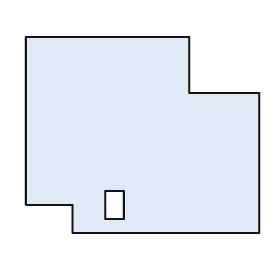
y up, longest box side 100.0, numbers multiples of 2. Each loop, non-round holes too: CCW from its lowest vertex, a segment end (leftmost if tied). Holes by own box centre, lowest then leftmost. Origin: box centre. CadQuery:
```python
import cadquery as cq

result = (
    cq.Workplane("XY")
    .moveTo(-30.0, -42.0)
    .lineTo(50.0, -42.0)
    .lineTo(50.0, 18.0)
    .lineTo(20.0, 18.0)
    .lineTo(20.0, 42.0)
    .lineTo(-50.0, 42.0)
    .lineTo(-50.0, -30.0)
    .lineTo(-30.0, -30.0)
    .close()
    .moveTo(-16.0, -36.0)
    .lineTo(-8.0, -36.0)
    .lineTo(-8.0, -24.0)
    .lineTo(-16.0, -24.0)
    .close()
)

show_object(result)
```